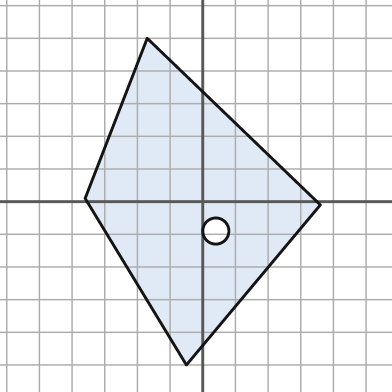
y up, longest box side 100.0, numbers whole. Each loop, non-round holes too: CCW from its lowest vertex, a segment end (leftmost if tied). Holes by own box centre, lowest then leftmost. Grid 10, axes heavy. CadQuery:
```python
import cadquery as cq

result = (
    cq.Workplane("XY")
    .moveTo(-5.0, -50.0)
    .lineTo(36.0, -1.0)
    .lineTo(-17.0, 50.0)
    .lineTo(-36.0, 1.0)
    .close()
    .moveTo(4.0, -9.0)
    .circle(4.0)
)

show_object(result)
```